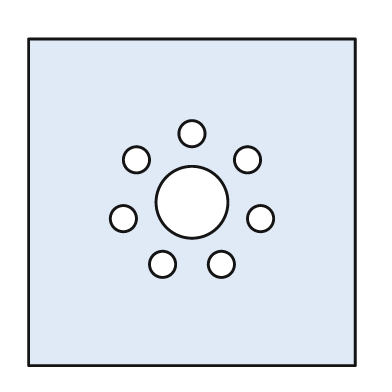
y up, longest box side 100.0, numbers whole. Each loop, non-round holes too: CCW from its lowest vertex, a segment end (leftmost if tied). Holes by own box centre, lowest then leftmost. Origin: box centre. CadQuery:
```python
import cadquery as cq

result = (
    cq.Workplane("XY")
    .moveTo(-50.0, -50.0)
    .lineTo(50.0, -50.0)
    .lineTo(50.0, 50.0)
    .lineTo(-50.0, 50.0)
    .close()
    .moveTo(-9.0, -19.0)
    .circle(4.0)
    .moveTo(9.0, -19.0)
    .circle(4.0)
    .moveTo(-21.0, -5.0)
    .circle(4.0)
    .moveTo(21.0, -5.0)
    .circle(4.0)
    .moveTo(0.0, 0.0)
    .circle(11.0)
    .moveTo(-17.0, 13.0)
    .circle(4.0)
    .moveTo(17.0, 13.0)
    .circle(4.0)
    .moveTo(0.0, 21.0)
    .circle(4.0)
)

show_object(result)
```